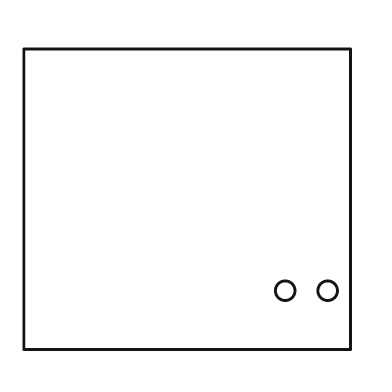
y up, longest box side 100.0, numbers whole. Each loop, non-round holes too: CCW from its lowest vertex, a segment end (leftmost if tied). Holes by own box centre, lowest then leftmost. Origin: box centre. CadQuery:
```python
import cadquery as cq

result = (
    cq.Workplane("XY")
    .moveTo(-50.0, -46.0)
    .lineTo(50.0, -46.0)
    .lineTo(50.0, 46.0)
    .lineTo(-50.0, 46.0)
    .close()
    .moveTo(30.0, -28.0)
    .circle(3.0)
    .moveTo(43.0, -28.0)
    .circle(3.0)
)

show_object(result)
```